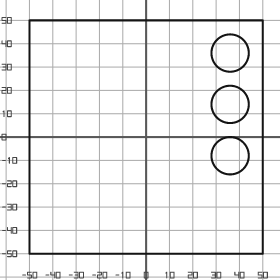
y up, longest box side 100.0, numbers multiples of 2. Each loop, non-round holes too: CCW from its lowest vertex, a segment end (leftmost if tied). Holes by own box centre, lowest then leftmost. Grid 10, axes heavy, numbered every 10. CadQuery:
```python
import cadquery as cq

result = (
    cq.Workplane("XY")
    .moveTo(-50.0, -50.0)
    .lineTo(50.0, -50.0)
    .lineTo(50.0, 50.0)
    .lineTo(-50.0, 50.0)
    .close()
    .moveTo(36.0, -8.0)
    .circle(8.0)
    .moveTo(36.0, 14.0)
    .circle(8.0)
    .moveTo(36.0, 36.0)
    .circle(8.0)
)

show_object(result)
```